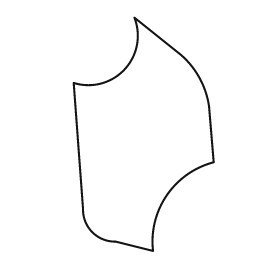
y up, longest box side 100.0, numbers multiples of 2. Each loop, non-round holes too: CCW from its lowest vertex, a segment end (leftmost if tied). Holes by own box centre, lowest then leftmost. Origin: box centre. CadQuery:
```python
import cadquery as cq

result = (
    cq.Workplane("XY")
    .moveTo(4.0, -50.0)
    .threePointArc((10.0, -26.0), (30.0, -12.0))
    .lineTo(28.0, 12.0)
    .threePointArc((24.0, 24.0), (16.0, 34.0))
    .lineTo(-4.0, 50.0)
    .threePointArc((-8.0, 28.0), (-30.0, 22.0))
    .lineTo(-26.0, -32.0)
    .threePointArc((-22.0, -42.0), (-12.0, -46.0))
    .close()
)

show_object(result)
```